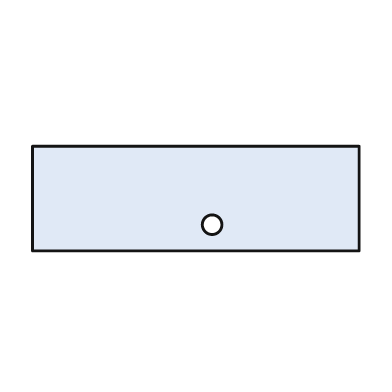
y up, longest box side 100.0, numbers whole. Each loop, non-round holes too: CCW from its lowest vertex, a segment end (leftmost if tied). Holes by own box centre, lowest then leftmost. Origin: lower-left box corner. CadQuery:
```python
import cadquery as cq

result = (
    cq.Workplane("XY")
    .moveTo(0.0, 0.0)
    .lineTo(100.0, 0.0)
    .lineTo(100.0, 32.0)
    .lineTo(0.0, 32.0)
    .close()
    .moveTo(55.0, 8.0)
    .circle(3.0)
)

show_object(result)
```